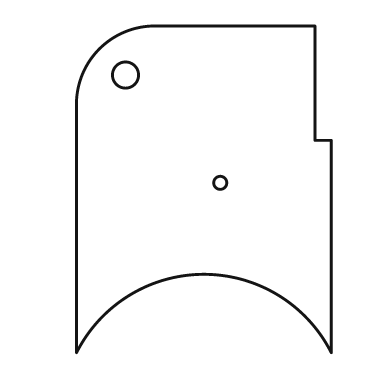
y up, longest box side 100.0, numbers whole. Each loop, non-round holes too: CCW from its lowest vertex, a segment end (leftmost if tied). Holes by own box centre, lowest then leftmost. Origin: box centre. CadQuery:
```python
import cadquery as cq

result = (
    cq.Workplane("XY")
    .moveTo(-39.0, -50.0)
    .threePointArc((0.0, -26.0), (39.0, -50.0))
    .lineTo(39.0, 15.0)
    .lineTo(34.0, 15.0)
    .lineTo(34.0, 50.0)
    .lineTo(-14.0, 50.0)
    .threePointArc((-32.0, 43.0), (-39.0, 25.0))
    .close()
    .moveTo(5.0, 2.0)
    .circle(2.0)
    .moveTo(-24.0, 35.0)
    .circle(4.0)
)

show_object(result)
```